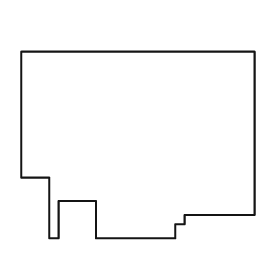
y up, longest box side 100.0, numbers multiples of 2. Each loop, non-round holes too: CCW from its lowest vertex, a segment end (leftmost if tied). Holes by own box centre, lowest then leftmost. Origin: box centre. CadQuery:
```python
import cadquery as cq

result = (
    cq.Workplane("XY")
    .moveTo(-38.0, -40.0)
    .lineTo(-34.0, -40.0)
    .lineTo(-34.0, -24.0)
    .lineTo(-18.0, -24.0)
    .lineTo(-18.0, -40.0)
    .lineTo(16.0, -40.0)
    .lineTo(16.0, -34.0)
    .lineTo(20.0, -34.0)
    .lineTo(20.0, -30.0)
    .lineTo(50.0, -30.0)
    .lineTo(50.0, 40.0)
    .lineTo(-50.0, 40.0)
    .lineTo(-50.0, -14.0)
    .lineTo(-38.0, -14.0)
    .close()
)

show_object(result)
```